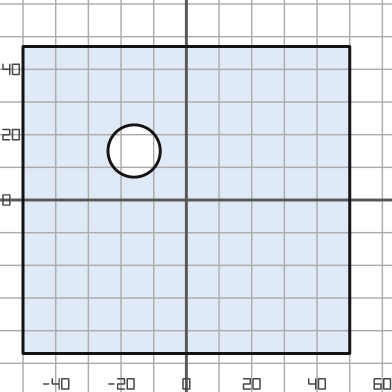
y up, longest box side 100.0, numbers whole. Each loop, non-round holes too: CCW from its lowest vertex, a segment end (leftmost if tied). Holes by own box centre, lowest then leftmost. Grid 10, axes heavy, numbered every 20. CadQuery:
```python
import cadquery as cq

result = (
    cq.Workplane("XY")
    .moveTo(-50.0, -47.0)
    .lineTo(50.0, -47.0)
    .lineTo(50.0, 47.0)
    .lineTo(-50.0, 47.0)
    .close()
    .moveTo(-16.0, 15.0)
    .circle(8.0)
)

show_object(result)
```